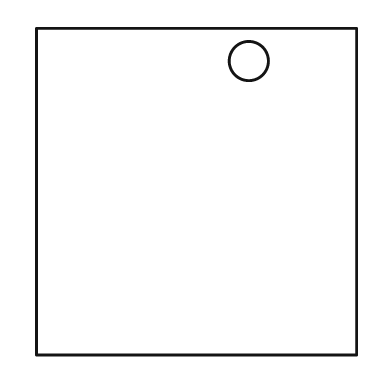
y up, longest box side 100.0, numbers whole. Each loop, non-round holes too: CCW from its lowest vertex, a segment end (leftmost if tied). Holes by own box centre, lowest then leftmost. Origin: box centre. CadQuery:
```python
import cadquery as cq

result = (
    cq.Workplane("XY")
    .moveTo(-49.0, -50.0)
    .lineTo(49.0, -50.0)
    .lineTo(49.0, 50.0)
    .lineTo(-49.0, 50.0)
    .close()
    .moveTo(16.0, 40.0)
    .circle(6.0)
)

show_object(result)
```